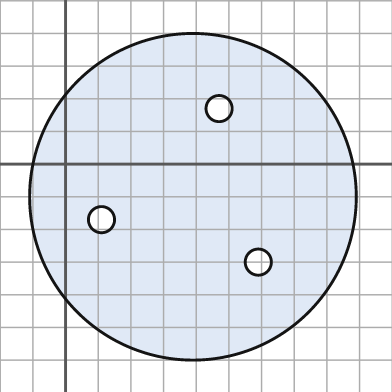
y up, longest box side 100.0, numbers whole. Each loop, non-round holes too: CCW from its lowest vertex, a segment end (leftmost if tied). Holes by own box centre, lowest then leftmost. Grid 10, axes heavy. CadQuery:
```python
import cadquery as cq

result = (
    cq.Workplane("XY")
    .moveTo(39.0, -10.0)
    .circle(50.0)
    .moveTo(59.0, -30.0)
    .circle(4.0)
    .moveTo(11.0, -17.0)
    .circle(4.0)
    .moveTo(47.0, 17.0)
    .circle(4.0)
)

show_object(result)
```